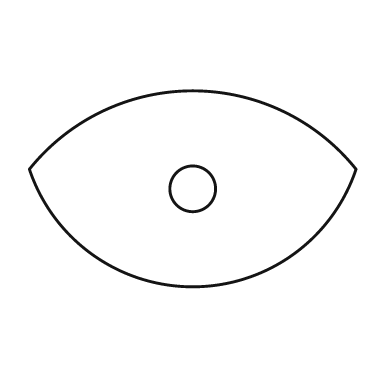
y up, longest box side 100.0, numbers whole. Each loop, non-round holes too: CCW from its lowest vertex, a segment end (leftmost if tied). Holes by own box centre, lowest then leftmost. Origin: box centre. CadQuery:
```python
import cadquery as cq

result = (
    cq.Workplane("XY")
    .moveTo(-50.0, 6.0)
    .threePointArc((0.0, -30.0), (50.0, 6.0))
    .threePointArc((0.0, 30.0), (-50.0, 6.0))
    .close()
    .moveTo(0.0, 0.0)
    .circle(7.0)
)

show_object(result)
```